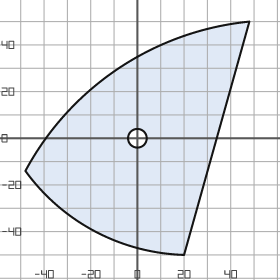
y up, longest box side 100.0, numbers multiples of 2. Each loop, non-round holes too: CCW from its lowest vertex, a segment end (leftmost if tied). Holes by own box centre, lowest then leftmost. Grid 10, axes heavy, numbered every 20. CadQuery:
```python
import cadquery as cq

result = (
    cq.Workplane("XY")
    .moveTo(20.0, -50.0)
    .lineTo(48.0, 50.0)
    .threePointArc((-8.0, 30.0), (-48.0, -14.0))
    .threePointArc((-18.0, -40.0), (20.0, -50.0))
    .close()
    .moveTo(0.0, 0.0)
    .circle(4.0)
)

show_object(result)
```